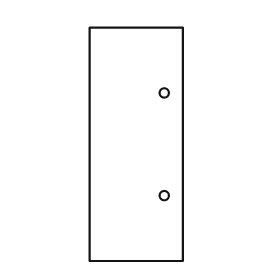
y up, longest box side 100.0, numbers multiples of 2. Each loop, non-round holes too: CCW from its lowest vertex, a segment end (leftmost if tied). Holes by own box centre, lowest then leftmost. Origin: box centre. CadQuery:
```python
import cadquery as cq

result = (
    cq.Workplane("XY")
    .moveTo(-20.0, -50.0)
    .lineTo(20.0, -50.0)
    .lineTo(20.0, 50.0)
    .lineTo(-20.0, 50.0)
    .close()
    .moveTo(12.0, -22.0)
    .circle(2.0)
    .moveTo(12.0, 22.0)
    .circle(2.0)
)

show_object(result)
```